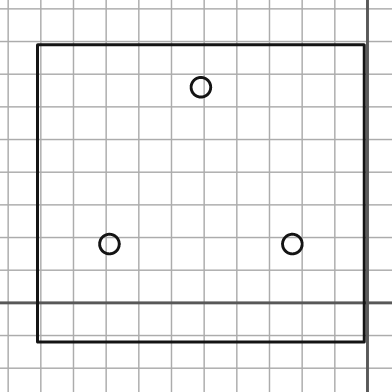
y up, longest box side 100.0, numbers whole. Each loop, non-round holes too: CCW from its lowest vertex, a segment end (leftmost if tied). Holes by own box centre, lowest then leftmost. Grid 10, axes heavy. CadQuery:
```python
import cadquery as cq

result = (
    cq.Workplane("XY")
    .moveTo(-101.0, -12.0)
    .lineTo(-1.0, -12.0)
    .lineTo(-1.0, 79.0)
    .lineTo(-101.0, 79.0)
    .close()
    .moveTo(-79.0, 18.0)
    .circle(3.0)
    .moveTo(-23.0, 18.0)
    .circle(3.0)
    .moveTo(-51.0, 66.0)
    .circle(3.0)
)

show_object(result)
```